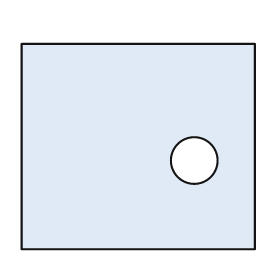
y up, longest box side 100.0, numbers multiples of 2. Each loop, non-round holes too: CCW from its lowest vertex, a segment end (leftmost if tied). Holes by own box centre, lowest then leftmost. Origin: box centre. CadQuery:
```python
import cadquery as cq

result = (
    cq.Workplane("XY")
    .moveTo(-50.0, -44.0)
    .lineTo(50.0, -44.0)
    .lineTo(50.0, 44.0)
    .lineTo(-50.0, 44.0)
    .close()
    .moveTo(24.0, -6.0)
    .circle(10.0)
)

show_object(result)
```